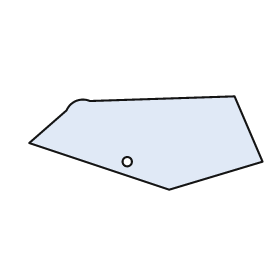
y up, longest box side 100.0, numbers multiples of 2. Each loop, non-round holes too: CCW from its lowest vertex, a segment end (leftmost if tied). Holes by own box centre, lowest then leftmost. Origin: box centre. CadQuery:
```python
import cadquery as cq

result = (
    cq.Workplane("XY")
    .moveTo(10.0, -20.0)
    .lineTo(50.0, -8.0)
    .lineTo(38.0, 20.0)
    .lineTo(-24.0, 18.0)
    .threePointArc((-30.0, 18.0), (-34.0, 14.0))
    .lineTo(-50.0, 0.0)
    .close()
    .moveTo(-8.0, -8.0)
    .circle(2.0)
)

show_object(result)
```